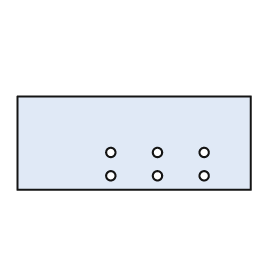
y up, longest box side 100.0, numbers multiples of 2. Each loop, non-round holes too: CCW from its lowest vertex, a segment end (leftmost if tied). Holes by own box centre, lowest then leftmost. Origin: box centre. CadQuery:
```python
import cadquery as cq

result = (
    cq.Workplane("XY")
    .moveTo(-50.0, -20.0)
    .lineTo(50.0, -20.0)
    .lineTo(50.0, 20.0)
    .lineTo(-50.0, 20.0)
    .close()
    .moveTo(-10.0, -14.0)
    .circle(2.0)
    .moveTo(10.0, -14.0)
    .circle(2.0)
    .moveTo(30.0, -14.0)
    .circle(2.0)
    .moveTo(-10.0, -4.0)
    .circle(2.0)
    .moveTo(10.0, -4.0)
    .circle(2.0)
    .moveTo(30.0, -4.0)
    .circle(2.0)
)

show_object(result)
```